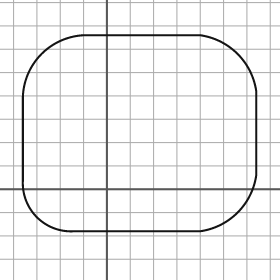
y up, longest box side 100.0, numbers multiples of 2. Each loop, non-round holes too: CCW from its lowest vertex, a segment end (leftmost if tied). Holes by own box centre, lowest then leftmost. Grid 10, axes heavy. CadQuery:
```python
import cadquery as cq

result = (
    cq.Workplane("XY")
    .moveTo(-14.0, -18.0)
    .lineTo(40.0, -18.0)
    .threePointArc((56.0, -10.0), (64.0, 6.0))
    .lineTo(64.0, 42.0)
    .threePointArc((56.0, 58.0), (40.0, 66.0))
    .lineTo(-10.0, 66.0)
    .threePointArc((-28.0, 58.0), (-36.0, 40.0))
    .lineTo(-36.0, 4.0)
    .threePointArc((-30.0, -12.0), (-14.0, -18.0))
    .close()
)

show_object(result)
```